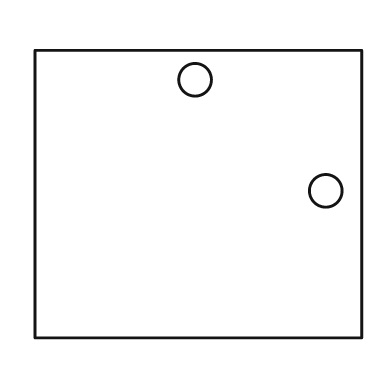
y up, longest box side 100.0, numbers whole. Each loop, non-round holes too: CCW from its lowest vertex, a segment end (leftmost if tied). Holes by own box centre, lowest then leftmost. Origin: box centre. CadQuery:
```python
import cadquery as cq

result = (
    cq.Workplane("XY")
    .moveTo(-50.0, -44.0)
    .lineTo(50.0, -44.0)
    .lineTo(50.0, 44.0)
    .lineTo(-50.0, 44.0)
    .close()
    .moveTo(39.0, 1.0)
    .circle(5.0)
    .moveTo(-1.0, 35.0)
    .circle(5.0)
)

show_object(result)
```